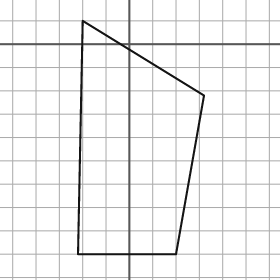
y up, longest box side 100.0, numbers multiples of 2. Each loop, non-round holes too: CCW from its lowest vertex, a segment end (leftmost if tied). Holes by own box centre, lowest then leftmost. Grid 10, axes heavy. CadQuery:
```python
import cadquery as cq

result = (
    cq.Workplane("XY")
    .moveTo(-22.0, -90.0)
    .lineTo(20.0, -90.0)
    .lineTo(32.0, -22.0)
    .lineTo(-20.0, 10.0)
    .close()
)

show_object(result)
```